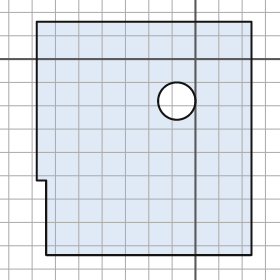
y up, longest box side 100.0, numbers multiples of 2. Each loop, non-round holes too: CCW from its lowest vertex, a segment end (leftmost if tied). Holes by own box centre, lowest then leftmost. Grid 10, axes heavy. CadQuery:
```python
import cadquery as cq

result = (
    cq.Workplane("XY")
    .moveTo(-64.0, -84.0)
    .lineTo(24.0, -84.0)
    .lineTo(24.0, 16.0)
    .lineTo(-68.0, 16.0)
    .lineTo(-68.0, -52.0)
    .lineTo(-64.0, -52.0)
    .close()
    .moveTo(-8.0, -18.0)
    .circle(8.0)
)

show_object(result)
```